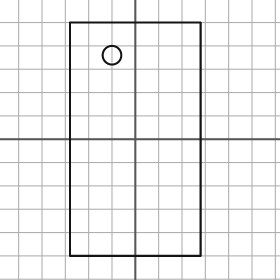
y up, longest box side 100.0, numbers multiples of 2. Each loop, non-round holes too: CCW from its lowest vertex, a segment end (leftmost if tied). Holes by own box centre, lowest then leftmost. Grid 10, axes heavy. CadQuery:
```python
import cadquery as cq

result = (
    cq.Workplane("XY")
    .moveTo(-28.0, -50.0)
    .lineTo(28.0, -50.0)
    .lineTo(28.0, 50.0)
    .lineTo(-28.0, 50.0)
    .close()
    .moveTo(-10.0, 36.0)
    .circle(4.0)
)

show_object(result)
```